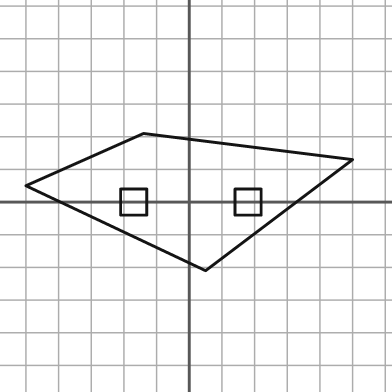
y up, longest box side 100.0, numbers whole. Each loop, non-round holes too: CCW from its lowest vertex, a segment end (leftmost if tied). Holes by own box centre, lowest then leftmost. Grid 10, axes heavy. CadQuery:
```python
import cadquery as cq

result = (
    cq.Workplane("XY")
    .moveTo(5.0, -21.0)
    .lineTo(50.0, 13.0)
    .lineTo(-14.0, 21.0)
    .lineTo(-50.0, 5.0)
    .close()
    .moveTo(-21.0, -4.0)
    .lineTo(-13.0, -4.0)
    .lineTo(-13.0, 4.0)
    .lineTo(-21.0, 4.0)
    .close()
    .moveTo(14.0, -4.0)
    .lineTo(22.0, -4.0)
    .lineTo(22.0, 4.0)
    .lineTo(14.0, 4.0)
    .close()
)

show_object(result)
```